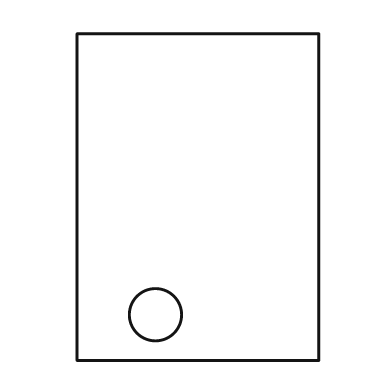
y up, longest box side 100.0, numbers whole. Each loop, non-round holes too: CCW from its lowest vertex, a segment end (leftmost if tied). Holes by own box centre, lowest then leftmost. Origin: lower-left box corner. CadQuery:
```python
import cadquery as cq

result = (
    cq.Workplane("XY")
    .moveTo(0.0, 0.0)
    .lineTo(74.0, 0.0)
    .lineTo(74.0, 100.0)
    .lineTo(0.0, 100.0)
    .close()
    .moveTo(24.0, 14.0)
    .circle(8.0)
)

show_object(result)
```